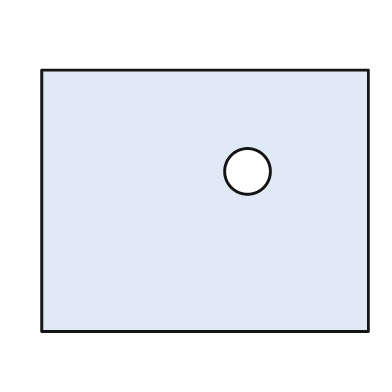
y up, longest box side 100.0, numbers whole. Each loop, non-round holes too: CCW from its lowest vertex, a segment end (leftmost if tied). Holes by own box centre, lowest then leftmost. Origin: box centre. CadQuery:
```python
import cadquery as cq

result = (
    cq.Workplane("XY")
    .moveTo(-50.0, -40.0)
    .lineTo(50.0, -40.0)
    .lineTo(50.0, 40.0)
    .lineTo(-50.0, 40.0)
    .close()
    .moveTo(13.0, 9.0)
    .circle(7.0)
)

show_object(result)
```